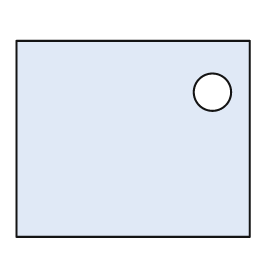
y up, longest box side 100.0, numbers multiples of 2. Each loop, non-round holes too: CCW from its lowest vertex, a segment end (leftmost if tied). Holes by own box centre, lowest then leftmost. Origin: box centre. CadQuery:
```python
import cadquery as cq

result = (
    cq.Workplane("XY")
    .moveTo(-50.0, -42.0)
    .lineTo(50.0, -42.0)
    .lineTo(50.0, 42.0)
    .lineTo(-50.0, 42.0)
    .close()
    .moveTo(34.0, 20.0)
    .circle(8.0)
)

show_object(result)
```